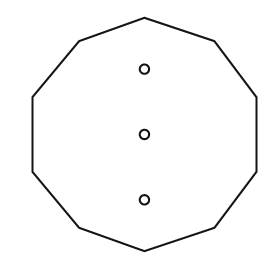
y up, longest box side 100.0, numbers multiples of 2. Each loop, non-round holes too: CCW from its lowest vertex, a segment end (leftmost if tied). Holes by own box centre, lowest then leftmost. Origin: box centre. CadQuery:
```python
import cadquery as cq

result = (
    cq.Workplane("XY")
    .moveTo(0.0, -50.0)
    .lineTo(30.0, -40.0)
    .lineTo(48.0, -16.0)
    .lineTo(48.0, 16.0)
    .lineTo(30.0, 40.0)
    .lineTo(0.0, 50.0)
    .lineTo(-28.0, 40.0)
    .lineTo(-48.0, 16.0)
    .lineTo(-48.0, -16.0)
    .lineTo(-28.0, -40.0)
    .close()
    .moveTo(0.0, -28.0)
    .circle(2.0)
    .moveTo(0.0, 0.0)
    .circle(2.0)
    .moveTo(0.0, 28.0)
    .circle(2.0)
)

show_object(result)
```